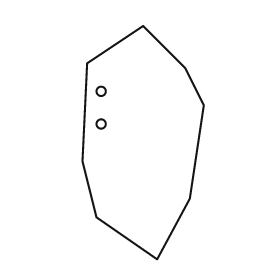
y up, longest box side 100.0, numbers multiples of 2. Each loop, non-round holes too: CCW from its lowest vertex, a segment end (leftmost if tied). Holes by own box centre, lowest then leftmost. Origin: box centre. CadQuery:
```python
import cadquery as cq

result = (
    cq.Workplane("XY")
    .moveTo(6.0, -50.0)
    .lineTo(20.0, -24.0)
    .lineTo(26.0, 16.0)
    .lineTo(18.0, 32.0)
    .lineTo(0.0, 50.0)
    .lineTo(-24.0, 34.0)
    .lineTo(-26.0, -8.0)
    .lineTo(-20.0, -32.0)
    .close()
    .moveTo(-18.0, 8.0)
    .circle(2.0)
    .moveTo(-18.0, 22.0)
    .circle(2.0)
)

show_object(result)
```